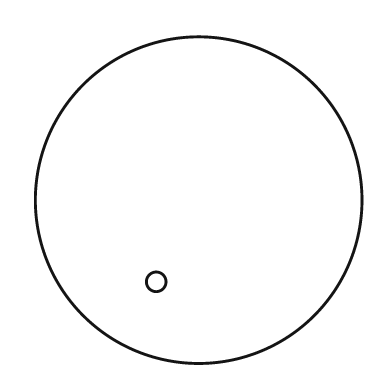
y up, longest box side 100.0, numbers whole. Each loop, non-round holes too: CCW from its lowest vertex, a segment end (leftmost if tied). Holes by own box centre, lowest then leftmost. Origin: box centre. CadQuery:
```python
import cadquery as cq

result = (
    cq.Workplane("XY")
    .moveTo(0.0, 0.0)
    .circle(50.0)
    .moveTo(-13.0, -25.0)
    .circle(3.0)
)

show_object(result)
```